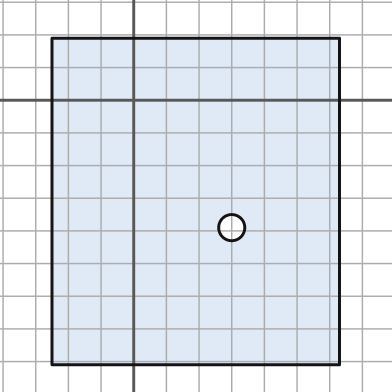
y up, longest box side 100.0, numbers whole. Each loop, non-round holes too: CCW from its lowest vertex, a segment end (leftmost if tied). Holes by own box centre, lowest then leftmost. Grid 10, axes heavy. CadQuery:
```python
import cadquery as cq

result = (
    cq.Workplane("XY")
    .moveTo(-25.0, -81.0)
    .lineTo(63.0, -81.0)
    .lineTo(63.0, 19.0)
    .lineTo(-25.0, 19.0)
    .close()
    .moveTo(30.0, -39.0)
    .circle(4.0)
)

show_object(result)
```